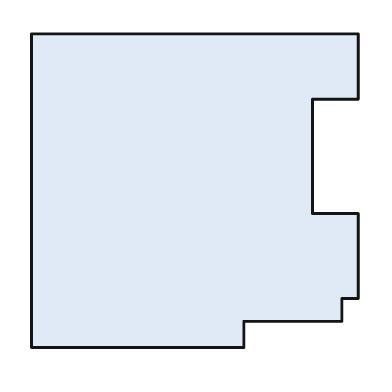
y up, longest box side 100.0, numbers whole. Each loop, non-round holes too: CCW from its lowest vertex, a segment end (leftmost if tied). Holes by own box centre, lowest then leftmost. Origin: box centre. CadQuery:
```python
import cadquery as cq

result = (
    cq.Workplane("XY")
    .moveTo(-50.0, -48.0)
    .lineTo(15.0, -48.0)
    .lineTo(15.0, -40.0)
    .lineTo(45.0, -40.0)
    .lineTo(45.0, -33.0)
    .lineTo(50.0, -33.0)
    .lineTo(50.0, -7.0)
    .lineTo(36.0, -7.0)
    .lineTo(36.0, 28.0)
    .lineTo(50.0, 28.0)
    .lineTo(50.0, 48.0)
    .lineTo(-50.0, 48.0)
    .close()
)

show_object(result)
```